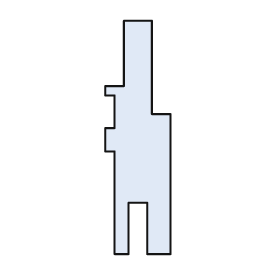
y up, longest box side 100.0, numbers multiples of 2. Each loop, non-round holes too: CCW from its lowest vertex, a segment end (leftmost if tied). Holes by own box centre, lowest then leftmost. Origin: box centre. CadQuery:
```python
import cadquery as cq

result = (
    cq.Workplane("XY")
    .moveTo(-10.0, -50.0)
    .lineTo(-4.0, -50.0)
    .lineTo(-4.0, -28.0)
    .lineTo(4.0, -28.0)
    .lineTo(4.0, -50.0)
    .lineTo(14.0, -50.0)
    .lineTo(14.0, 10.0)
    .lineTo(6.0, 10.0)
    .lineTo(6.0, 50.0)
    .lineTo(-6.0, 50.0)
    .lineTo(-6.0, 22.0)
    .lineTo(-14.0, 22.0)
    .lineTo(-14.0, 18.0)
    .lineTo(-10.0, 18.0)
    .lineTo(-10.0, 4.0)
    .lineTo(-14.0, 4.0)
    .lineTo(-14.0, -6.0)
    .lineTo(-10.0, -6.0)
    .close()
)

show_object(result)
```